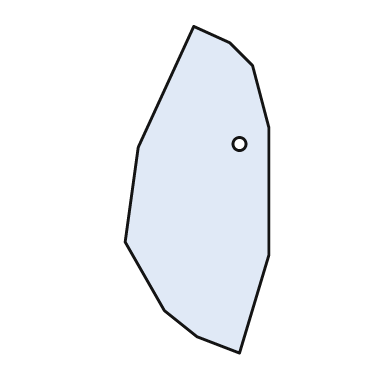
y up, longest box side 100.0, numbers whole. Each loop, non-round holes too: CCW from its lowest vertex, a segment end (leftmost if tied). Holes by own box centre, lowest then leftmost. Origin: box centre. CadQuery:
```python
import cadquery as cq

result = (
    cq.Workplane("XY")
    .moveTo(13.0, -50.0)
    .lineTo(22.0, -20.0)
    .lineTo(22.0, 19.0)
    .lineTo(17.0, 38.0)
    .lineTo(10.0, 45.0)
    .lineTo(-1.0, 50.0)
    .lineTo(-18.0, 13.0)
    .lineTo(-22.0, -16.0)
    .lineTo(-10.0, -37.0)
    .lineTo(0.0, -45.0)
    .close()
    .moveTo(13.0, 14.0)
    .circle(2.0)
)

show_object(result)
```